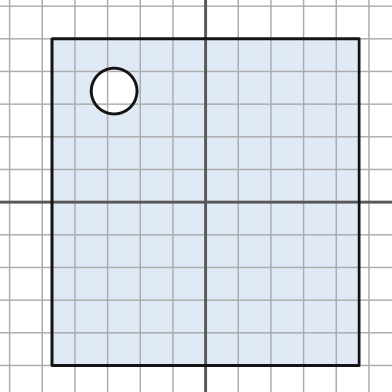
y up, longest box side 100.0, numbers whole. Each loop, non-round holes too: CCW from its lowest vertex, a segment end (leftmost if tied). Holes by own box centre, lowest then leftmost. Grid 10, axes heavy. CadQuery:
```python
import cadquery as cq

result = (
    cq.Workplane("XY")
    .moveTo(-47.0, -50.0)
    .lineTo(47.0, -50.0)
    .lineTo(47.0, 50.0)
    .lineTo(-47.0, 50.0)
    .close()
    .moveTo(-28.0, 34.0)
    .circle(7.0)
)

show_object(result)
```